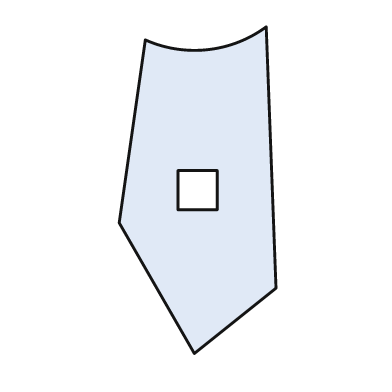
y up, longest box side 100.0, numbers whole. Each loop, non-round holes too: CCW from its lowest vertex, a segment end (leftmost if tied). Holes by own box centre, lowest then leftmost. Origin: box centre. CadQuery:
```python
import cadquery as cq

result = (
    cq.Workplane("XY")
    .moveTo(-1.0, -50.0)
    .lineTo(24.0, -30.0)
    .lineTo(21.0, 50.0)
    .threePointArc((3.0, 43.0), (-16.0, 46.0))
    .lineTo(-24.0, -10.0)
    .close()
    .moveTo(-6.0, -6.0)
    .lineTo(6.0, -6.0)
    .lineTo(6.0, 6.0)
    .lineTo(-6.0, 6.0)
    .close()
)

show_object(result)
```